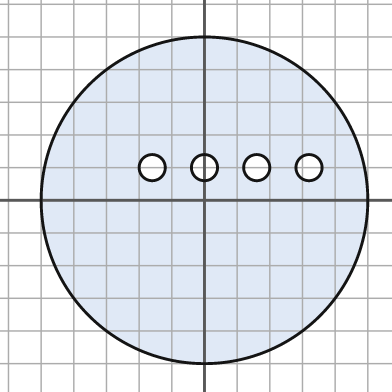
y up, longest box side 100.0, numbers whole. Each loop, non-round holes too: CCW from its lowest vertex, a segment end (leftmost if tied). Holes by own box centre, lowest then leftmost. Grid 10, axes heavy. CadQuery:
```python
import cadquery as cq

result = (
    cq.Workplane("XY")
    .moveTo(0.0, 0.0)
    .circle(50.0)
    .moveTo(-16.0, 10.0)
    .circle(4.0)
    .moveTo(0.0, 10.0)
    .circle(4.0)
    .moveTo(16.0, 10.0)
    .circle(4.0)
    .moveTo(32.0, 10.0)
    .circle(4.0)
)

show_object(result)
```